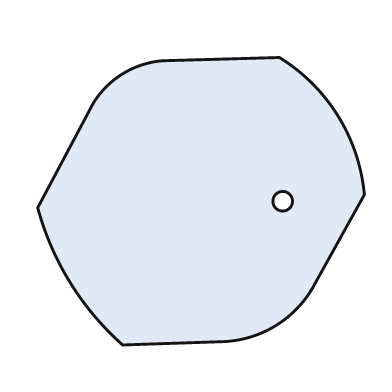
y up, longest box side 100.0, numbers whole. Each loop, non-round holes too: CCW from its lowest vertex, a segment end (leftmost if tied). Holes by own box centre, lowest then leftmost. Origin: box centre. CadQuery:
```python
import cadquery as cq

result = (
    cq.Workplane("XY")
    .moveTo(-24.0, -44.0)
    .lineTo(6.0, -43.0)
    .threePointArc((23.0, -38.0), (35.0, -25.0))
    .lineTo(50.0, 2.0)
    .threePointArc((42.0, 26.0), (24.0, 44.0))
    .lineTo(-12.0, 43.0)
    .threePointArc((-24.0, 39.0), (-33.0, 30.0))
    .lineTo(-50.0, -2.0)
    .threePointArc((-40.0, -25.0), (-24.0, -44.0))
    .close()
    .moveTo(25.0, 0.0)
    .circle(3.0)
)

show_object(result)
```